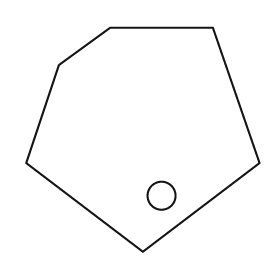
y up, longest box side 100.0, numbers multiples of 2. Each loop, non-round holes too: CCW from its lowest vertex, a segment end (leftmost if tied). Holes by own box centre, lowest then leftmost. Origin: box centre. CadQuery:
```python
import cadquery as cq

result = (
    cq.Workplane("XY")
    .moveTo(0.0, -48.0)
    .lineTo(50.0, -10.0)
    .lineTo(30.0, 48.0)
    .lineTo(-14.0, 48.0)
    .lineTo(-36.0, 32.0)
    .lineTo(-50.0, -10.0)
    .close()
    .moveTo(8.0, -24.0)
    .circle(6.0)
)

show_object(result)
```